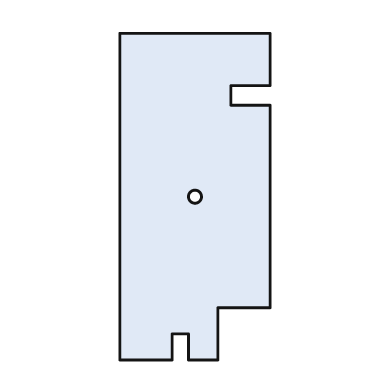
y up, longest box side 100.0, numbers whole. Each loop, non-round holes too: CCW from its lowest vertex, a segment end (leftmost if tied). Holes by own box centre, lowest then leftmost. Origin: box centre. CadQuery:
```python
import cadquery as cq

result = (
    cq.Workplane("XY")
    .moveTo(-23.0, -50.0)
    .lineTo(-7.0, -50.0)
    .lineTo(-7.0, -42.0)
    .lineTo(-2.0, -42.0)
    .lineTo(-2.0, -50.0)
    .lineTo(7.0, -50.0)
    .lineTo(7.0, -34.0)
    .lineTo(23.0, -34.0)
    .lineTo(23.0, 28.0)
    .lineTo(11.0, 28.0)
    .lineTo(11.0, 34.0)
    .lineTo(23.0, 34.0)
    .lineTo(23.0, 50.0)
    .lineTo(-23.0, 50.0)
    .close()
    .moveTo(0.0, 0.0)
    .circle(2.0)
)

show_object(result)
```